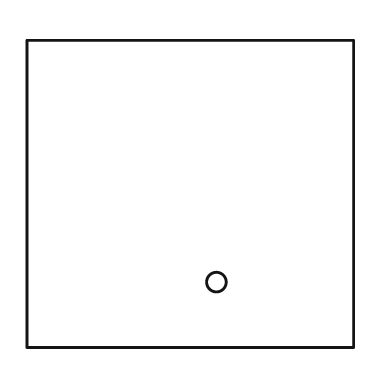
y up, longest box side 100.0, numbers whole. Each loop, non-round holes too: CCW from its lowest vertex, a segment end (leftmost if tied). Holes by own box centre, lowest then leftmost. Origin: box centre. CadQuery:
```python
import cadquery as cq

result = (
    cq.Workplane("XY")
    .moveTo(-50.0, -47.0)
    .lineTo(50.0, -47.0)
    .lineTo(50.0, 47.0)
    .lineTo(-50.0, 47.0)
    .close()
    .moveTo(8.0, -27.0)
    .circle(3.0)
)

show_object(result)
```